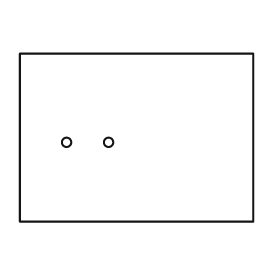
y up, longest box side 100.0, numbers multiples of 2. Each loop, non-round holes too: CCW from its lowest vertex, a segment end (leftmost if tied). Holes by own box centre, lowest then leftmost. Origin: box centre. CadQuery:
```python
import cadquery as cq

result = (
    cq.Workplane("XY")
    .moveTo(-50.0, -36.0)
    .lineTo(50.0, -36.0)
    .lineTo(50.0, 36.0)
    .lineTo(-50.0, 36.0)
    .close()
    .moveTo(-30.0, -2.0)
    .circle(2.0)
    .moveTo(-12.0, -2.0)
    .circle(2.0)
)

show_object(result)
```